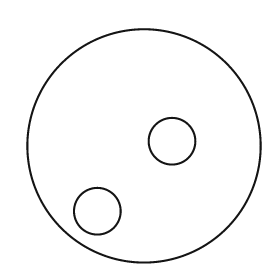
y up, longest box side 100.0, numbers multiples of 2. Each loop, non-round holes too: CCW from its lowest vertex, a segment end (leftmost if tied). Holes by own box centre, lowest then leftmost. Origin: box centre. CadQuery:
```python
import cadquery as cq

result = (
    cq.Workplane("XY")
    .moveTo(0.0, 0.0)
    .circle(50.0)
    .moveTo(-20.0, -28.0)
    .circle(10.0)
    .moveTo(12.0, 2.0)
    .circle(10.0)
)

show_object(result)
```